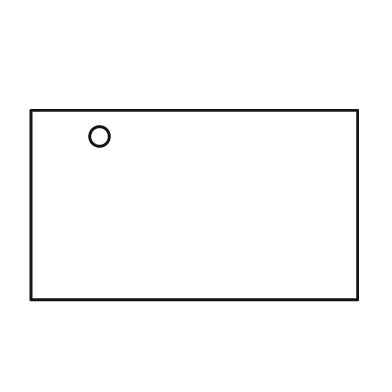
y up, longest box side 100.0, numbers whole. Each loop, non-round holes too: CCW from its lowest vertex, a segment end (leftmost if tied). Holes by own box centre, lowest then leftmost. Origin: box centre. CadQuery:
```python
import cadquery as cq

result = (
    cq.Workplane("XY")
    .moveTo(-50.0, -29.0)
    .lineTo(50.0, -29.0)
    .lineTo(50.0, 29.0)
    .lineTo(-50.0, 29.0)
    .close()
    .moveTo(-29.0, 21.0)
    .circle(3.0)
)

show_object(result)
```